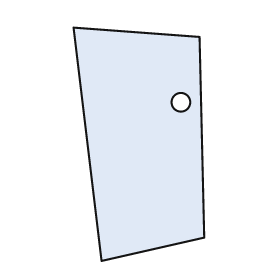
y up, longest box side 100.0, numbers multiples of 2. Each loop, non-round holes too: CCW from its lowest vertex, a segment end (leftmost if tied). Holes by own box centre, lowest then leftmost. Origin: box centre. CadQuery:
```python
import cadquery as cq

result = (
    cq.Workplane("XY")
    .moveTo(-16.0, -50.0)
    .lineTo(28.0, -40.0)
    .lineTo(26.0, 46.0)
    .lineTo(-28.0, 50.0)
    .close()
    .moveTo(18.0, 18.0)
    .circle(4.0)
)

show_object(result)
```